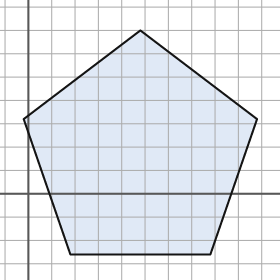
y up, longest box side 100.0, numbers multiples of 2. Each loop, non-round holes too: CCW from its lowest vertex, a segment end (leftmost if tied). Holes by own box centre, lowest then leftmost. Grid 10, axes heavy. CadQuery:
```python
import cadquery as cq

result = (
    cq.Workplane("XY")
    .moveTo(18.0, -26.0)
    .lineTo(78.0, -26.0)
    .lineTo(98.0, 32.0)
    .lineTo(48.0, 70.0)
    .lineTo(-2.0, 32.0)
    .close()
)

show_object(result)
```